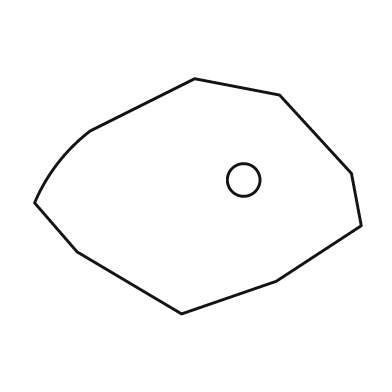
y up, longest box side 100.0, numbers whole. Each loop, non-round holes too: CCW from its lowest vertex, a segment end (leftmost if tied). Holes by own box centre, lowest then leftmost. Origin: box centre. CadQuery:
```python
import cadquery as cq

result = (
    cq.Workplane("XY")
    .moveTo(-5.0, -36.0)
    .lineTo(24.0, -26.0)
    .lineTo(50.0, -9.0)
    .lineTo(47.0, 7.0)
    .lineTo(25.0, 31.0)
    .lineTo(-1.0, 36.0)
    .lineTo(-33.0, 20.0)
    .threePointArc((-43.0, 10.0), (-50.0, -2.0))
    .lineTo(-37.0, -17.0)
    .close()
    .moveTo(14.0, 5.0)
    .circle(5.0)
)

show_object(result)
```